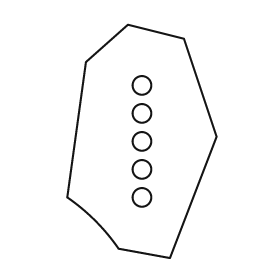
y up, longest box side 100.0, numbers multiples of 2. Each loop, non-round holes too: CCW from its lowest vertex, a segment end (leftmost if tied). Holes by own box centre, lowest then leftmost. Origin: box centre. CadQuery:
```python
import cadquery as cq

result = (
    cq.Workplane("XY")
    .moveTo(12.0, -50.0)
    .lineTo(32.0, 2.0)
    .lineTo(18.0, 44.0)
    .lineTo(-6.0, 50.0)
    .lineTo(-24.0, 34.0)
    .lineTo(-32.0, -24.0)
    .threePointArc((-20.0, -34.0), (-10.0, -46.0))
    .close()
    .moveTo(0.0, -24.0)
    .circle(4.0)
    .moveTo(0.0, -12.0)
    .circle(4.0)
    .moveTo(0.0, 0.0)
    .circle(4.0)
    .moveTo(0.0, 12.0)
    .circle(4.0)
    .moveTo(0.0, 24.0)
    .circle(4.0)
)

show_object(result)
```